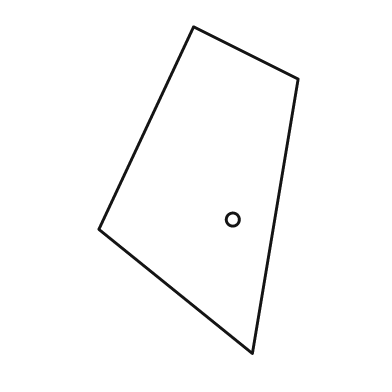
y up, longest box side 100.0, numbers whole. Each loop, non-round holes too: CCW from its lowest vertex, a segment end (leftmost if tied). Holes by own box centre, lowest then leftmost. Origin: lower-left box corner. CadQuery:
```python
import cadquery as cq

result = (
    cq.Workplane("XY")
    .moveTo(47.0, 0.0)
    .lineTo(61.0, 84.0)
    .lineTo(29.0, 100.0)
    .lineTo(0.0, 38.0)
    .close()
    .moveTo(41.0, 41.0)
    .circle(2.0)
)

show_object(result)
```